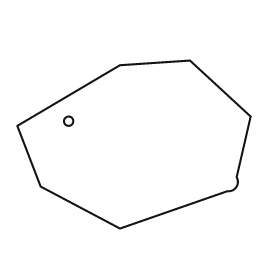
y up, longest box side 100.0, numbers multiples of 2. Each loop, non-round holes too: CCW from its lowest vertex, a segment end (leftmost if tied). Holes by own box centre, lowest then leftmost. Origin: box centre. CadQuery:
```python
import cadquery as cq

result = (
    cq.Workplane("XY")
    .moveTo(-6.0, -36.0)
    .lineTo(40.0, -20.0)
    .threePointArc((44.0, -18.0), (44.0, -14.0))
    .lineTo(50.0, 12.0)
    .lineTo(24.0, 36.0)
    .lineTo(-6.0, 34.0)
    .lineTo(-50.0, 8.0)
    .lineTo(-40.0, -18.0)
    .close()
    .moveTo(-28.0, 10.0)
    .circle(2.0)
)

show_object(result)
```